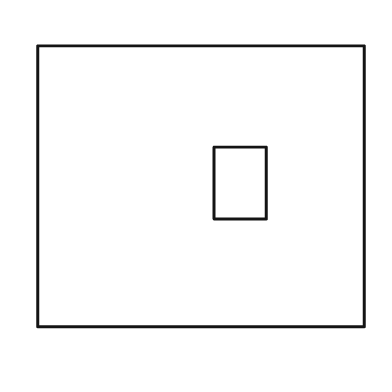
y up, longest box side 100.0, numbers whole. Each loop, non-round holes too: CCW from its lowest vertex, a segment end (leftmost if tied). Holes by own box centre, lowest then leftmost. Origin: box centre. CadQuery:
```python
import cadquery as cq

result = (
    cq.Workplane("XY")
    .moveTo(-50.0, -43.0)
    .lineTo(50.0, -43.0)
    .lineTo(50.0, 43.0)
    .lineTo(-50.0, 43.0)
    .close()
    .moveTo(4.0, -10.0)
    .lineTo(20.0, -10.0)
    .lineTo(20.0, 12.0)
    .lineTo(4.0, 12.0)
    .close()
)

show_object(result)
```